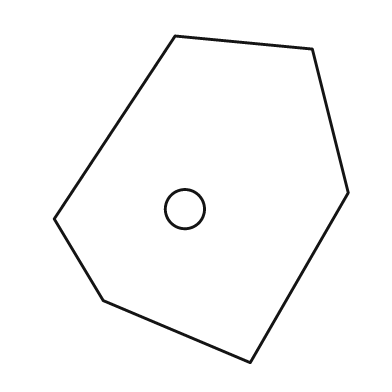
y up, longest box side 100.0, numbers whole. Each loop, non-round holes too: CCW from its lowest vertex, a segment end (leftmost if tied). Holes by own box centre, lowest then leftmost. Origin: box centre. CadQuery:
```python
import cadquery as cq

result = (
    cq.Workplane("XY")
    .moveTo(15.0, -50.0)
    .lineTo(45.0, 2.0)
    .lineTo(34.0, 46.0)
    .lineTo(-8.0, 50.0)
    .lineTo(-45.0, -6.0)
    .lineTo(-30.0, -31.0)
    .close()
    .moveTo(-5.0, -3.0)
    .circle(6.0)
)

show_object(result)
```